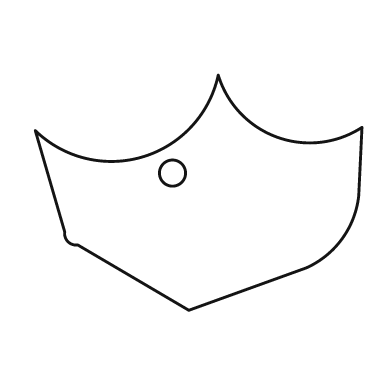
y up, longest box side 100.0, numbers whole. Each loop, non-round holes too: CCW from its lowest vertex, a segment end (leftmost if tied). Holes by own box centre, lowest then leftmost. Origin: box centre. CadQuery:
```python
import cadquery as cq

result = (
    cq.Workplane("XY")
    .moveTo(-3.0, -36.0)
    .lineTo(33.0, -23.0)
    .threePointArc((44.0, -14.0), (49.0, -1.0))
    .lineTo(50.0, 20.0)
    .threePointArc((24.0, 17.0), (6.0, 36.0))
    .threePointArc((-17.0, 11.0), (-50.0, 19.0))
    .lineTo(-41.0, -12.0)
    .threePointArc((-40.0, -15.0), (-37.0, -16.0))
    .close()
    .moveTo(-8.0, 6.0)
    .circle(4.0)
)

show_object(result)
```